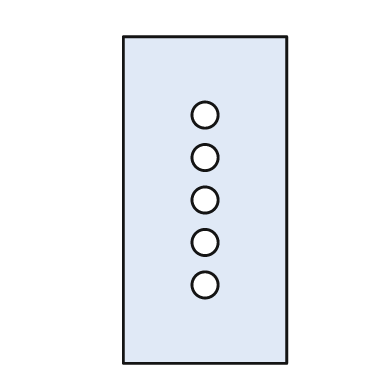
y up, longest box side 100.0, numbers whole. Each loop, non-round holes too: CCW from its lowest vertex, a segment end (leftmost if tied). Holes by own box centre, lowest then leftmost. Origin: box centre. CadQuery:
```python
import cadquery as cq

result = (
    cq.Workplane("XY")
    .moveTo(-25.0, -50.0)
    .lineTo(25.0, -50.0)
    .lineTo(25.0, 50.0)
    .lineTo(-25.0, 50.0)
    .close()
    .moveTo(0.0, -26.0)
    .circle(4.0)
    .moveTo(0.0, -13.0)
    .circle(4.0)
    .moveTo(0.0, 0.0)
    .circle(4.0)
    .moveTo(0.0, 13.0)
    .circle(4.0)
    .moveTo(0.0, 26.0)
    .circle(4.0)
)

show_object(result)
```